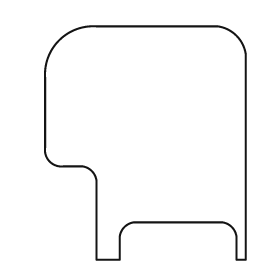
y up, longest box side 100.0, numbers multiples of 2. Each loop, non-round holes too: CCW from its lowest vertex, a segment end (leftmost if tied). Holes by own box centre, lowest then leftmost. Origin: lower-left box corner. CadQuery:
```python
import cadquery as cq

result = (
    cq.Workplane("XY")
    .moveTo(22.0, 0.0)
    .lineTo(32.0, 0.0)
    .lineTo(32.0, 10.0)
    .threePointArc((34.0, 14.0), (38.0, 16.0))
    .lineTo(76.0, 16.0)
    .threePointArc((80.0, 14.0), (82.0, 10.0))
    .lineTo(82.0, 0.0)
    .lineTo(86.0, 0.0)
    .lineTo(86.0, 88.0)
    .threePointArc((82.0, 96.0), (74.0, 100.0))
    .lineTo(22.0, 100.0)
    .threePointArc((6.0, 94.0), (0.0, 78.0))
    .lineTo(0.0, 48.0)
    .threePointArc((2.0, 42.0), (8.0, 40.0))
    .lineTo(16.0, 40.0)
    .threePointArc((20.0, 38.0), (22.0, 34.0))
    .close()
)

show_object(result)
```